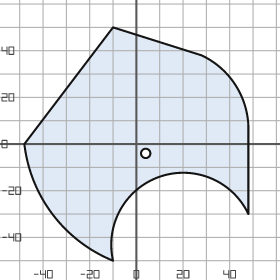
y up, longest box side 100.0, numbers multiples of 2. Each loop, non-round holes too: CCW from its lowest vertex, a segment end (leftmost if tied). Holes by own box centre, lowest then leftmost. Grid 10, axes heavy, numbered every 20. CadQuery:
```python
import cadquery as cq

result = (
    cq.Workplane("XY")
    .moveTo(-10.0, -50.0)
    .threePointArc((10.0, -14.0), (48.0, -30.0))
    .lineTo(48.0, 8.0)
    .threePointArc((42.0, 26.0), (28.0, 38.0))
    .lineTo(-10.0, 50.0)
    .lineTo(-48.0, 0.0)
    .threePointArc((-36.0, -30.0), (-10.0, -50.0))
    .close()
    .moveTo(4.0, -4.0)
    .circle(2.0)
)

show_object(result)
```